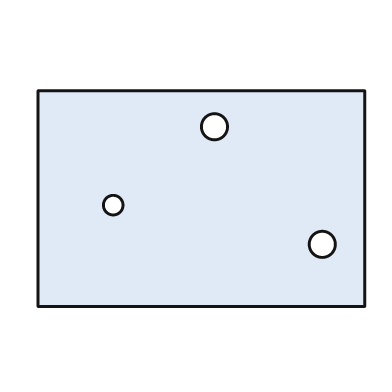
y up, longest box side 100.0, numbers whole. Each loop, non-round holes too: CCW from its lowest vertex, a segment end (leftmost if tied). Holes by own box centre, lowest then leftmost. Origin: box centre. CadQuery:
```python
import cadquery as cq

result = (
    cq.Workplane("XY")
    .moveTo(-50.0, -33.0)
    .lineTo(50.0, -33.0)
    .lineTo(50.0, 33.0)
    .lineTo(-50.0, 33.0)
    .close()
    .moveTo(37.0, -14.0)
    .circle(4.0)
    .moveTo(-27.0, -2.0)
    .circle(3.0)
    .moveTo(4.0, 22.0)
    .circle(4.0)
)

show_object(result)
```